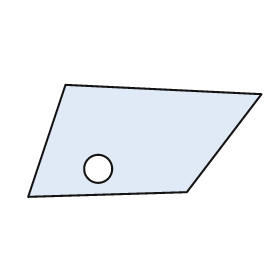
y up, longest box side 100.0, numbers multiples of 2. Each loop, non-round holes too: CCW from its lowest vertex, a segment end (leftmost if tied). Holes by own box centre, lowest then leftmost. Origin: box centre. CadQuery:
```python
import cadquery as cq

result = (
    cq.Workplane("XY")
    .moveTo(-50.0, -24.0)
    .lineTo(18.0, -22.0)
    .lineTo(50.0, 20.0)
    .lineTo(-34.0, 24.0)
    .close()
    .moveTo(-20.0, -12.0)
    .circle(6.0)
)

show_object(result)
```